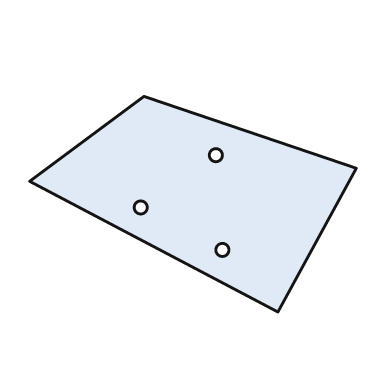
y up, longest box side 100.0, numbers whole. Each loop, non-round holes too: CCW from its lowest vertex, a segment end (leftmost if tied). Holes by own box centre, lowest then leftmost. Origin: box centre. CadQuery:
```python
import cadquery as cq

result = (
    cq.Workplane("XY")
    .moveTo(26.0, -33.0)
    .lineTo(50.0, 11.0)
    .lineTo(-15.0, 33.0)
    .lineTo(-50.0, 7.0)
    .close()
    .moveTo(9.0, -14.0)
    .circle(2.0)
    .moveTo(-16.0, -1.0)
    .circle(2.0)
    .moveTo(7.0, 15.0)
    .circle(2.0)
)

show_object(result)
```